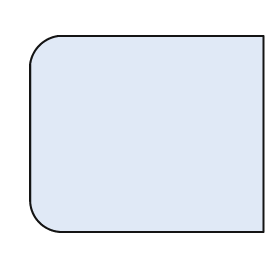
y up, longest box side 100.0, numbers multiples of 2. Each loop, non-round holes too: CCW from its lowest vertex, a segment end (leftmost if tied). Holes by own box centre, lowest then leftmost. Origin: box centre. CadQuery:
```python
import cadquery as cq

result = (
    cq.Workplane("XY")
    .moveTo(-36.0, -42.0)
    .lineTo(50.0, -42.0)
    .lineTo(50.0, 42.0)
    .lineTo(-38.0, 42.0)
    .threePointArc((-46.0, 38.0), (-50.0, 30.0))
    .lineTo(-50.0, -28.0)
    .threePointArc((-46.0, -38.0), (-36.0, -42.0))
    .close()
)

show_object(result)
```